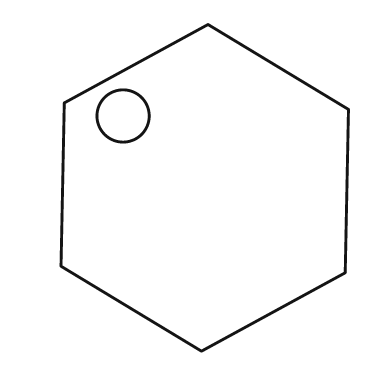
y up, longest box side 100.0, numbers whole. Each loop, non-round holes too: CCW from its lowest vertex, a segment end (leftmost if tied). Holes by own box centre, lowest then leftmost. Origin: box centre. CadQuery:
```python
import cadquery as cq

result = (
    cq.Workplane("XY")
    .moveTo(-1.0, -50.0)
    .lineTo(43.0, -26.0)
    .lineTo(44.0, 24.0)
    .lineTo(1.0, 50.0)
    .lineTo(-43.0, 26.0)
    .lineTo(-44.0, -24.0)
    .close()
    .moveTo(-25.0, 22.0)
    .circle(8.0)
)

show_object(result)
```